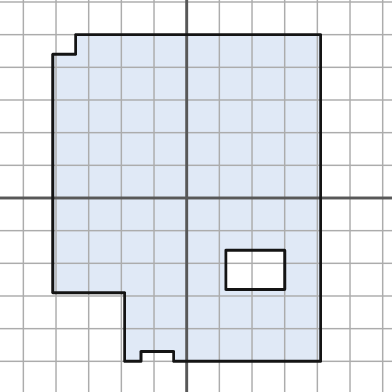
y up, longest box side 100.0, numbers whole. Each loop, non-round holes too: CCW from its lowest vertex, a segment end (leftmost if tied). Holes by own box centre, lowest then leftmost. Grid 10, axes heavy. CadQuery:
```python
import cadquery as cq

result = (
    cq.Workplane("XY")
    .moveTo(-19.0, -50.0)
    .lineTo(-14.0, -50.0)
    .lineTo(-14.0, -47.0)
    .lineTo(-4.0, -47.0)
    .lineTo(-4.0, -50.0)
    .lineTo(41.0, -50.0)
    .lineTo(41.0, 50.0)
    .lineTo(-34.0, 50.0)
    .lineTo(-34.0, 44.0)
    .lineTo(-41.0, 44.0)
    .lineTo(-41.0, -29.0)
    .lineTo(-19.0, -29.0)
    .close()
    .moveTo(12.0, -28.0)
    .lineTo(30.0, -28.0)
    .lineTo(30.0, -16.0)
    .lineTo(12.0, -16.0)
    .close()
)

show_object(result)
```